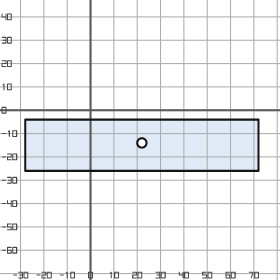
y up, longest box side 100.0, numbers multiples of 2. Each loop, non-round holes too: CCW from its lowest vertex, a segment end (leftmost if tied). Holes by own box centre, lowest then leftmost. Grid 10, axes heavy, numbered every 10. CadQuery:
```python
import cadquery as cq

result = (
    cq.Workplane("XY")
    .moveTo(-28.0, -26.0)
    .lineTo(72.0, -26.0)
    .lineTo(72.0, -4.0)
    .lineTo(-28.0, -4.0)
    .close()
    .moveTo(22.0, -14.0)
    .circle(2.0)
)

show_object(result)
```